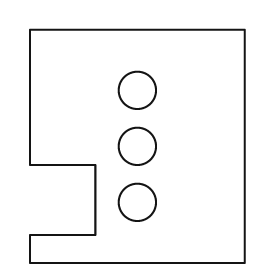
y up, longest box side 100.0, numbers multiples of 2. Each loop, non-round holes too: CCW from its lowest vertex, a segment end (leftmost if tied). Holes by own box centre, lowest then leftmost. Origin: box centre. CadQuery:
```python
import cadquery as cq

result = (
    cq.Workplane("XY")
    .moveTo(-46.0, -50.0)
    .lineTo(46.0, -50.0)
    .lineTo(46.0, 50.0)
    .lineTo(-46.0, 50.0)
    .lineTo(-46.0, -8.0)
    .lineTo(-18.0, -8.0)
    .lineTo(-18.0, -38.0)
    .lineTo(-46.0, -38.0)
    .close()
    .moveTo(0.0, -24.0)
    .circle(8.0)
    .moveTo(0.0, 0.0)
    .circle(8.0)
    .moveTo(0.0, 24.0)
    .circle(8.0)
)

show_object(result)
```